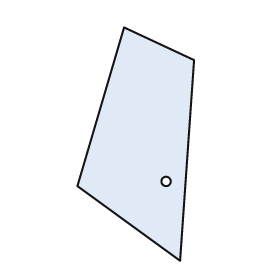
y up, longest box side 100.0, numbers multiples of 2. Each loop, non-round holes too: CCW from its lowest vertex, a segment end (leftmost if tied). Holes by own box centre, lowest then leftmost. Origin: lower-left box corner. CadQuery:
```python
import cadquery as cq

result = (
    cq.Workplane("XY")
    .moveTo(44.0, 0.0)
    .lineTo(50.0, 86.0)
    .lineTo(20.0, 100.0)
    .lineTo(0.0, 32.0)
    .close()
    .moveTo(38.0, 34.0)
    .circle(2.0)
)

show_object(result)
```